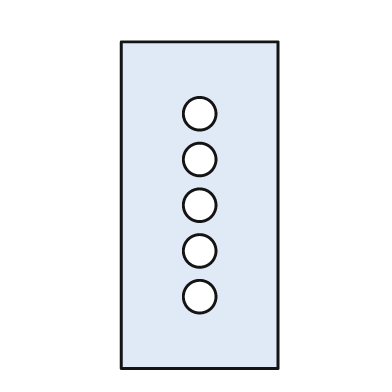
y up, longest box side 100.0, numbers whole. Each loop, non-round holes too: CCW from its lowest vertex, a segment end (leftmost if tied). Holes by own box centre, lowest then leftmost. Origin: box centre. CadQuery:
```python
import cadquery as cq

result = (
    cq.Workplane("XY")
    .moveTo(-24.0, -50.0)
    .lineTo(24.0, -50.0)
    .lineTo(24.0, 50.0)
    .lineTo(-24.0, 50.0)
    .close()
    .moveTo(0.0, -28.0)
    .circle(5.0)
    .moveTo(0.0, -14.0)
    .circle(5.0)
    .moveTo(0.0, 0.0)
    .circle(5.0)
    .moveTo(0.0, 14.0)
    .circle(5.0)
    .moveTo(0.0, 28.0)
    .circle(5.0)
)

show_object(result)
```